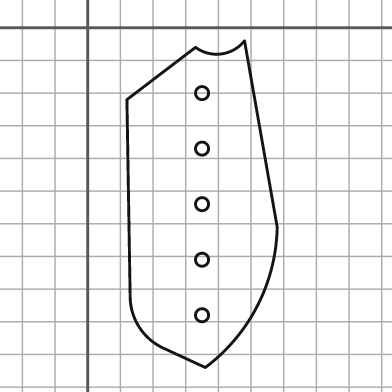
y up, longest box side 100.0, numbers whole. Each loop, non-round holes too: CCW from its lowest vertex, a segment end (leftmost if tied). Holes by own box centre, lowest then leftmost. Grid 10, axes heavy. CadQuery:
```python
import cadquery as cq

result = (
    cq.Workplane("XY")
    .moveTo(36.0, -104.0)
    .threePointArc((52.0, -85.0), (58.0, -61.0))
    .lineTo(48.0, -4.0)
    .threePointArc((41.0, -8.0), (33.0, -6.0))
    .lineTo(12.0, -22.0)
    .lineTo(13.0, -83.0)
    .threePointArc((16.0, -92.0), (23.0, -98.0))
    .close()
    .moveTo(35.0, -88.0)
    .circle(2.0)
    .moveTo(35.0, -71.0)
    .circle(2.0)
    .moveTo(35.0, -54.0)
    .circle(2.0)
    .moveTo(35.0, -37.0)
    .circle(2.0)
    .moveTo(35.0, -20.0)
    .circle(2.0)
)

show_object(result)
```